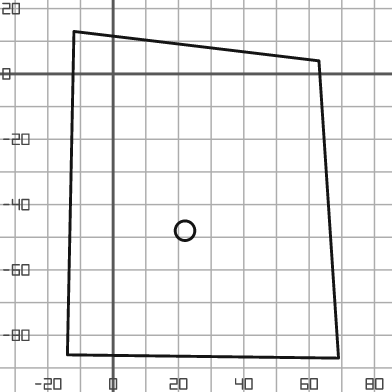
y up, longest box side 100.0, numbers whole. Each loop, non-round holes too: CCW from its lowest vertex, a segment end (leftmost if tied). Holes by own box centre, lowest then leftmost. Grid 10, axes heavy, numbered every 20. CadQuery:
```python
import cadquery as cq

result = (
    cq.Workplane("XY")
    .moveTo(69.0, -87.0)
    .lineTo(63.0, 4.0)
    .lineTo(-12.0, 13.0)
    .lineTo(-14.0, -86.0)
    .close()
    .moveTo(22.0, -48.0)
    .circle(3.0)
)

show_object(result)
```